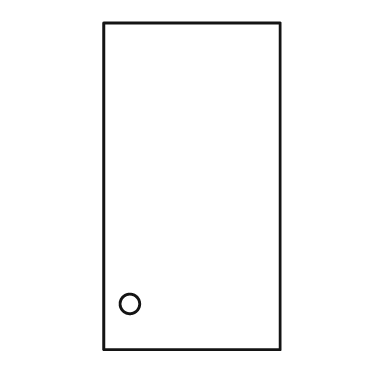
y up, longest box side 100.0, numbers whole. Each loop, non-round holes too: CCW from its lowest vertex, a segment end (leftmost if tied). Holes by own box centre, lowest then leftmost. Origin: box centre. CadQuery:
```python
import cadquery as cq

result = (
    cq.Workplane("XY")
    .moveTo(-27.0, -50.0)
    .lineTo(27.0, -50.0)
    .lineTo(27.0, 50.0)
    .lineTo(-27.0, 50.0)
    .close()
    .moveTo(-19.0, -36.0)
    .circle(3.0)
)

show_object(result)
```